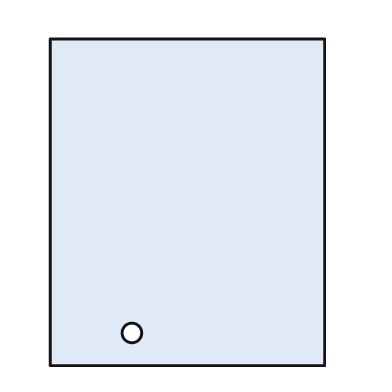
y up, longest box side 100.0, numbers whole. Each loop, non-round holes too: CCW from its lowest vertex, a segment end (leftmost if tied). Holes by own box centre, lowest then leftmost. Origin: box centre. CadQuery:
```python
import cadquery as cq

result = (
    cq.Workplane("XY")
    .moveTo(-42.0, -50.0)
    .lineTo(42.0, -50.0)
    .lineTo(42.0, 50.0)
    .lineTo(-42.0, 50.0)
    .close()
    .moveTo(-17.0, -40.0)
    .circle(3.0)
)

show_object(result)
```